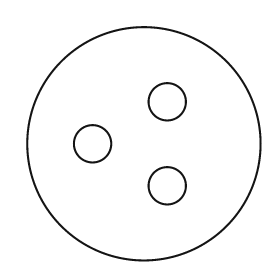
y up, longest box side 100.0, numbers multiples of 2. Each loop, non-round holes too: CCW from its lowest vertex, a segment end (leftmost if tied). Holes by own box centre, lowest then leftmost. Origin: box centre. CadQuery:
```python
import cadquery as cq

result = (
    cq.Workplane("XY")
    .moveTo(0.0, 0.0)
    .circle(50.0)
    .moveTo(10.0, -18.0)
    .circle(8.0)
    .moveTo(-22.0, 0.0)
    .circle(8.0)
    .moveTo(10.0, 18.0)
    .circle(8.0)
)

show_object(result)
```